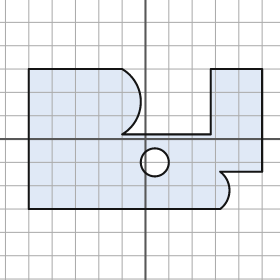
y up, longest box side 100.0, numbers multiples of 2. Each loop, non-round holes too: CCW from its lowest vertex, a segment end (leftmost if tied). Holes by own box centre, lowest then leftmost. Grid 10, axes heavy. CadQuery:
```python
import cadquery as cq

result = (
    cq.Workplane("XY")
    .moveTo(-50.0, -30.0)
    .lineTo(32.0, -30.0)
    .threePointArc((36.0, -22.0), (32.0, -14.0))
    .lineTo(50.0, -14.0)
    .lineTo(50.0, 30.0)
    .lineTo(28.0, 30.0)
    .lineTo(28.0, 2.0)
    .lineTo(-10.0, 2.0)
    .threePointArc((-2.0, 16.0), (-10.0, 30.0))
    .lineTo(-50.0, 30.0)
    .close()
    .moveTo(4.0, -10.0)
    .circle(6.0)
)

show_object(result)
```